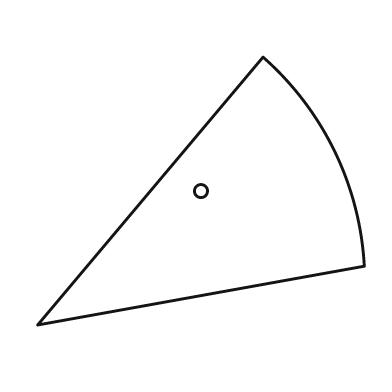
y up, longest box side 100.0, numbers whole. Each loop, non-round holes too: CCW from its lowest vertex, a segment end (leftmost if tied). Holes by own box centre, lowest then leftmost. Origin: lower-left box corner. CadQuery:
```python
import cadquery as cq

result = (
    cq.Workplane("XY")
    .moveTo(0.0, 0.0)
    .lineTo(100.0, 18.0)
    .threePointArc((91.0, 53.0), (69.0, 82.0))
    .close()
    .moveTo(50.0, 41.0)
    .circle(2.0)
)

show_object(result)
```